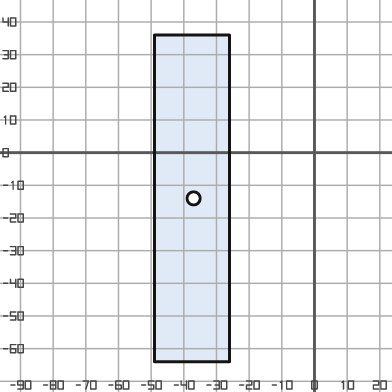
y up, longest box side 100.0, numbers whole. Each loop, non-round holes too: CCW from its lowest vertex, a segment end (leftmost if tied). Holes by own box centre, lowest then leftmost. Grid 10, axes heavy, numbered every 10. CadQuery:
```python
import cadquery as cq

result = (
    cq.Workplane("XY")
    .moveTo(-49.0, -64.0)
    .lineTo(-26.0, -64.0)
    .lineTo(-26.0, 36.0)
    .lineTo(-49.0, 36.0)
    .close()
    .moveTo(-37.0, -14.0)
    .circle(2.0)
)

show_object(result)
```